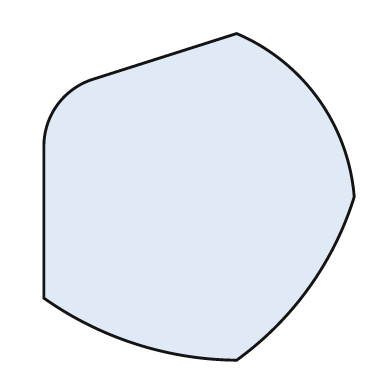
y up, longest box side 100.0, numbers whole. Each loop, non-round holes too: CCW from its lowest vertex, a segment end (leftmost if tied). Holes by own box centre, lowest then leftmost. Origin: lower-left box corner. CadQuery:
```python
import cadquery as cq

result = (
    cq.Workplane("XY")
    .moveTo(59.0, 0.0)
    .threePointArc((81.0, 22.0), (95.0, 50.0))
    .threePointArc((84.0, 80.0), (59.0, 100.0))
    .lineTo(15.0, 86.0)
    .threePointArc((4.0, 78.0), (0.0, 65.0))
    .lineTo(0.0, 19.0)
    .threePointArc((28.0, 5.0), (59.0, 0.0))
    .close()
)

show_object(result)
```